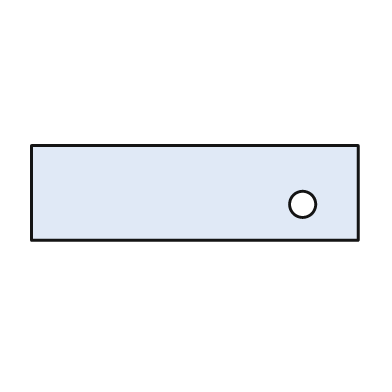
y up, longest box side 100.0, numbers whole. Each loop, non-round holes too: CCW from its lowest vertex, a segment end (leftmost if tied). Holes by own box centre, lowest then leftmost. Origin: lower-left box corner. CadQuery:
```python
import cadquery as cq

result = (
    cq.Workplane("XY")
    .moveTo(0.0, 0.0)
    .lineTo(100.0, 0.0)
    .lineTo(100.0, 29.0)
    .lineTo(0.0, 29.0)
    .close()
    .moveTo(83.0, 11.0)
    .circle(4.0)
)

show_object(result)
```